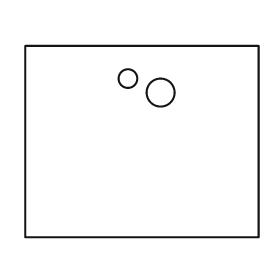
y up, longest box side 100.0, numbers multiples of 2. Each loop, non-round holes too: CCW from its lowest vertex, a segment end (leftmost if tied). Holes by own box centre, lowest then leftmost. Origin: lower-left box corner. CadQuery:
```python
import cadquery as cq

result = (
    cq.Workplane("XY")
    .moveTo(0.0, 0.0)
    .lineTo(100.0, 0.0)
    .lineTo(100.0, 82.0)
    .lineTo(0.0, 82.0)
    .close()
    .moveTo(58.0, 62.0)
    .circle(6.0)
    .moveTo(44.0, 68.0)
    .circle(4.0)
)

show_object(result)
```